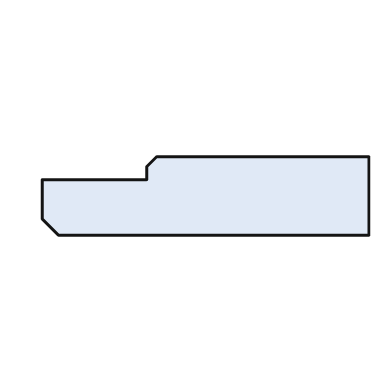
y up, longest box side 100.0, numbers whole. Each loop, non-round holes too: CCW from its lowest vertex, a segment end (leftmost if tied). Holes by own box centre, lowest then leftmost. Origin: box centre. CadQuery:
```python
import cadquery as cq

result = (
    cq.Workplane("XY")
    .moveTo(-45.0, -12.0)
    .lineTo(50.0, -12.0)
    .lineTo(50.0, 12.0)
    .lineTo(-15.0, 12.0)
    .lineTo(-18.0, 9.0)
    .lineTo(-18.0, 5.0)
    .lineTo(-50.0, 5.0)
    .lineTo(-50.0, -7.0)
    .close()
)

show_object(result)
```